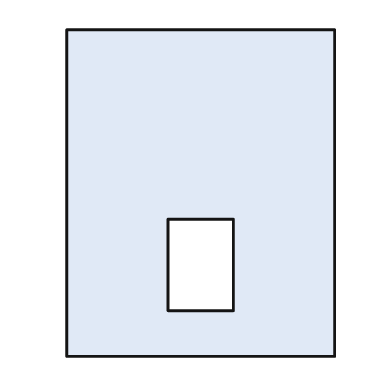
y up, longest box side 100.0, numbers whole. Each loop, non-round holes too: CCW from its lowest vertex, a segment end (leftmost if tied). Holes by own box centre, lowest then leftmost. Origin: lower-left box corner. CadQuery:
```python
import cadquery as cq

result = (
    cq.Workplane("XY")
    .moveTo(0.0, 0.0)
    .lineTo(82.0, 0.0)
    .lineTo(82.0, 100.0)
    .lineTo(0.0, 100.0)
    .close()
    .moveTo(31.0, 14.0)
    .lineTo(51.0, 14.0)
    .lineTo(51.0, 42.0)
    .lineTo(31.0, 42.0)
    .close()
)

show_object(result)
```